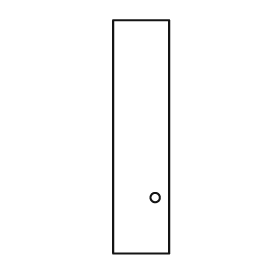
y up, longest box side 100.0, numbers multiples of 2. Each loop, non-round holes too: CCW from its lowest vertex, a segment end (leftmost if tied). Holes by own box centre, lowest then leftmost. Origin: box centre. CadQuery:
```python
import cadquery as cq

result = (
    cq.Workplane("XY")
    .moveTo(-12.0, -50.0)
    .lineTo(12.0, -50.0)
    .lineTo(12.0, 50.0)
    .lineTo(-12.0, 50.0)
    .close()
    .moveTo(6.0, -26.0)
    .circle(2.0)
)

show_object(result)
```